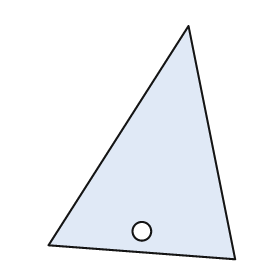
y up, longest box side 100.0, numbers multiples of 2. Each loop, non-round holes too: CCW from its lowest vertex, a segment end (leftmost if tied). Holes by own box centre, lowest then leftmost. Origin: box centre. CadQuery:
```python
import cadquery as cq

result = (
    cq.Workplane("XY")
    .moveTo(40.0, -50.0)
    .lineTo(20.0, 50.0)
    .lineTo(-40.0, -44.0)
    .close()
    .moveTo(0.0, -38.0)
    .circle(4.0)
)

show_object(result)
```